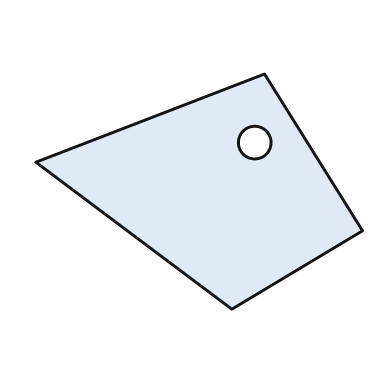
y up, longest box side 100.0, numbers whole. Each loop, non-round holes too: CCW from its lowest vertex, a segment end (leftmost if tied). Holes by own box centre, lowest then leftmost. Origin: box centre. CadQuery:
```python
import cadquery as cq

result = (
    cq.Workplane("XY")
    .moveTo(10.0, -36.0)
    .lineTo(50.0, -12.0)
    .lineTo(20.0, 36.0)
    .lineTo(-50.0, 9.0)
    .close()
    .moveTo(17.0, 15.0)
    .circle(5.0)
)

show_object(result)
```